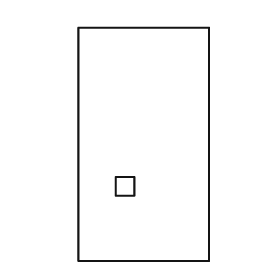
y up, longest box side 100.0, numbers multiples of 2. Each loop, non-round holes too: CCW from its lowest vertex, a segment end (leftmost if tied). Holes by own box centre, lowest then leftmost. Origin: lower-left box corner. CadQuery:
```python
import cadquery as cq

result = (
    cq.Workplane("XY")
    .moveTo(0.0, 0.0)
    .lineTo(56.0, 0.0)
    .lineTo(56.0, 100.0)
    .lineTo(0.0, 100.0)
    .close()
    .moveTo(16.0, 28.0)
    .lineTo(24.0, 28.0)
    .lineTo(24.0, 36.0)
    .lineTo(16.0, 36.0)
    .close()
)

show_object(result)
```